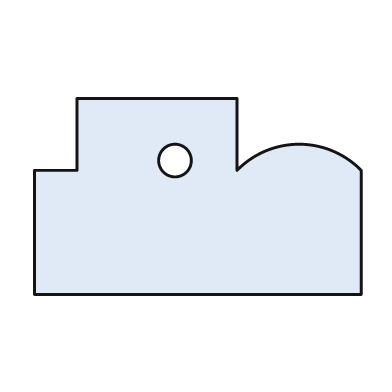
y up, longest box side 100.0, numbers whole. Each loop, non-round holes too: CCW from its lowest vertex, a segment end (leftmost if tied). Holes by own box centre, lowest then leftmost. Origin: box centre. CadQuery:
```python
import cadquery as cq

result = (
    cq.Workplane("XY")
    .moveTo(-50.0, -30.0)
    .lineTo(50.0, -30.0)
    .lineTo(50.0, 8.0)
    .threePointArc((31.0, 16.0), (12.0, 8.0))
    .lineTo(12.0, 30.0)
    .lineTo(-37.0, 30.0)
    .lineTo(-37.0, 8.0)
    .lineTo(-50.0, 8.0)
    .close()
    .moveTo(-7.0, 11.0)
    .circle(5.0)
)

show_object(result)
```